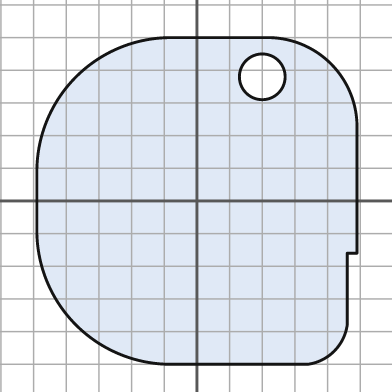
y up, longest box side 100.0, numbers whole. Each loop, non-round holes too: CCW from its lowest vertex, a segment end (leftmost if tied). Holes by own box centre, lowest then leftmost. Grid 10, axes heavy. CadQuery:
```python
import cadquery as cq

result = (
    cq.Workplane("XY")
    .moveTo(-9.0, -50.0)
    .lineTo(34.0, -50.0)
    .threePointArc((42.0, -46.0), (46.0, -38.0))
    .lineTo(46.0, -16.0)
    .lineTo(49.0, -16.0)
    .lineTo(49.0, 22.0)
    .threePointArc((41.0, 42.0), (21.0, 50.0))
    .lineTo(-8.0, 50.0)
    .threePointArc((-37.0, 38.0), (-49.0, 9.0))
    .lineTo(-49.0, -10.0)
    .threePointArc((-37.0, -38.0), (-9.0, -50.0))
    .close()
    .moveTo(20.0, 38.0)
    .circle(7.0)
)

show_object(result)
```